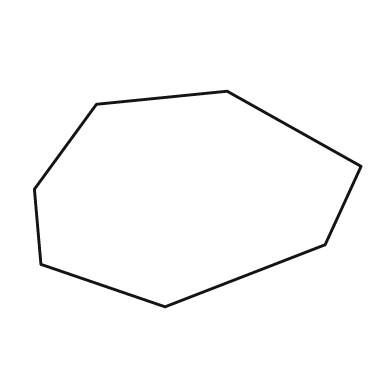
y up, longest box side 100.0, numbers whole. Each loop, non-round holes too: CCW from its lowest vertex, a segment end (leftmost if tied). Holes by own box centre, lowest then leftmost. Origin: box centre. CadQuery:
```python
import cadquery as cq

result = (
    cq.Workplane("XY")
    .moveTo(-10.0, -33.0)
    .lineTo(39.0, -14.0)
    .lineTo(50.0, 10.0)
    .lineTo(9.0, 33.0)
    .lineTo(-31.0, 29.0)
    .lineTo(-50.0, 3.0)
    .lineTo(-48.0, -20.0)
    .close()
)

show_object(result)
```